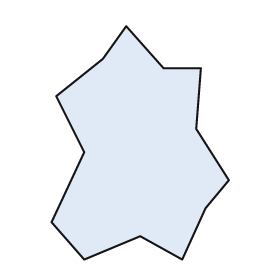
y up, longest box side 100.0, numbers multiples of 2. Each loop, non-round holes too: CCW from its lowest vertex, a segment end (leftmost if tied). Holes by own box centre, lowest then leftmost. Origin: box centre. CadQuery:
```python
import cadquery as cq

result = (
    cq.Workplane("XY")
    .moveTo(-24.0, -50.0)
    .lineTo(0.0, -40.0)
    .lineTo(18.0, -50.0)
    .lineTo(28.0, -28.0)
    .lineTo(38.0, -16.0)
    .lineTo(24.0, 6.0)
    .lineTo(26.0, 32.0)
    .lineTo(10.0, 32.0)
    .lineTo(-6.0, 50.0)
    .lineTo(-16.0, 36.0)
    .lineTo(-36.0, 20.0)
    .lineTo(-24.0, -4.0)
    .lineTo(-38.0, -34.0)
    .close()
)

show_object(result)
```